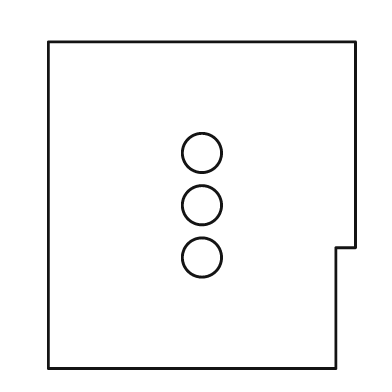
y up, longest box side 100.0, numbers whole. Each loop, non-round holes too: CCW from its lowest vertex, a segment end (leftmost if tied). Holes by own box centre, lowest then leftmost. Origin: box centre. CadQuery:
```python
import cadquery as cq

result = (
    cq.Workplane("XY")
    .moveTo(-47.0, -50.0)
    .lineTo(41.0, -50.0)
    .lineTo(41.0, -13.0)
    .lineTo(47.0, -13.0)
    .lineTo(47.0, 50.0)
    .lineTo(-47.0, 50.0)
    .close()
    .moveTo(0.0, -16.0)
    .circle(6.0)
    .moveTo(0.0, 0.0)
    .circle(6.0)
    .moveTo(0.0, 16.0)
    .circle(6.0)
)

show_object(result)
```